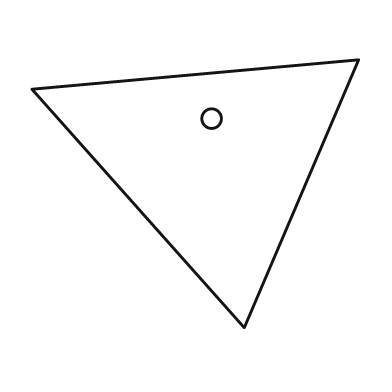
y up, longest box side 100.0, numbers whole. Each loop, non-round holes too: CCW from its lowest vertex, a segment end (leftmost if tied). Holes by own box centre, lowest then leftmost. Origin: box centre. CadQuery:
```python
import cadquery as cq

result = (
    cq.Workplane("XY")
    .moveTo(15.0, -41.0)
    .lineTo(50.0, 41.0)
    .lineTo(-50.0, 32.0)
    .close()
    .moveTo(5.0, 23.0)
    .circle(3.0)
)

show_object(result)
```